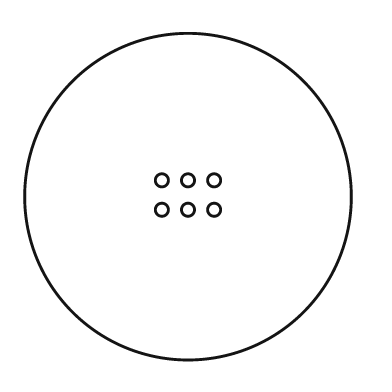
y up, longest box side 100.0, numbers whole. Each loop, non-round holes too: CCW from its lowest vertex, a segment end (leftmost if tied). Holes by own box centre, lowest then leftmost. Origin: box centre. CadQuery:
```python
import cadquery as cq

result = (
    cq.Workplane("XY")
    .moveTo(0.0, 0.0)
    .circle(50.0)
    .moveTo(-8.0, -4.0)
    .circle(2.0)
    .moveTo(0.0, -4.0)
    .circle(2.0)
    .moveTo(8.0, -4.0)
    .circle(2.0)
    .moveTo(-8.0, 5.0)
    .circle(2.0)
    .moveTo(0.0, 5.0)
    .circle(2.0)
    .moveTo(8.0, 5.0)
    .circle(2.0)
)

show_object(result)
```